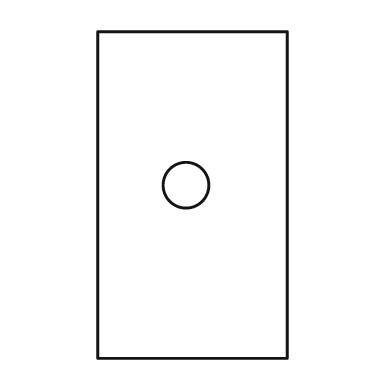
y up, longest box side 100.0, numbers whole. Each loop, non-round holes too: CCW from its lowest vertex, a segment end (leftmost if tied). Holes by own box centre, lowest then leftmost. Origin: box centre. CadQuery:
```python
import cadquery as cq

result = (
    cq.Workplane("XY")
    .moveTo(-29.0, -50.0)
    .lineTo(29.0, -50.0)
    .lineTo(29.0, 50.0)
    .lineTo(-29.0, 50.0)
    .close()
    .moveTo(-2.0, 3.0)
    .circle(7.0)
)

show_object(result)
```